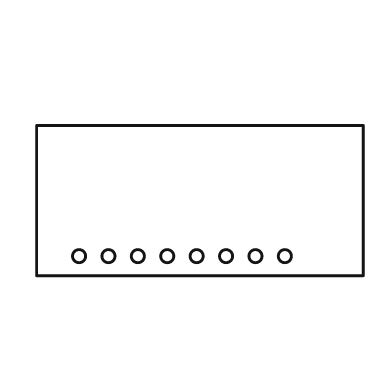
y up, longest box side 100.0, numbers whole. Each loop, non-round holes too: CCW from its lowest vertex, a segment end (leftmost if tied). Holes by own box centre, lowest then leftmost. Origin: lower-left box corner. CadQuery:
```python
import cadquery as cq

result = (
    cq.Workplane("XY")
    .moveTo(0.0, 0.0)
    .lineTo(100.0, 0.0)
    .lineTo(100.0, 46.0)
    .lineTo(0.0, 46.0)
    .close()
    .moveTo(13.0, 6.0)
    .circle(2.0)
    .moveTo(22.0, 6.0)
    .circle(2.0)
    .moveTo(31.0, 6.0)
    .circle(2.0)
    .moveTo(40.0, 6.0)
    .circle(2.0)
    .moveTo(49.0, 6.0)
    .circle(2.0)
    .moveTo(58.0, 6.0)
    .circle(2.0)
    .moveTo(67.0, 6.0)
    .circle(2.0)
    .moveTo(76.0, 6.0)
    .circle(2.0)
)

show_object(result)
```